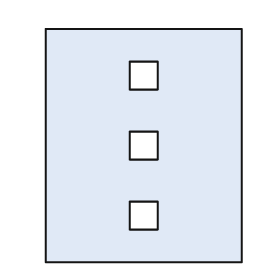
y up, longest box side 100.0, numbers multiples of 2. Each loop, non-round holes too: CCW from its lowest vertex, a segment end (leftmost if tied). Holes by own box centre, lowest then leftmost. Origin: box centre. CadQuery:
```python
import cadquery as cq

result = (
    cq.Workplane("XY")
    .moveTo(-42.0, -50.0)
    .lineTo(42.0, -50.0)
    .lineTo(42.0, 50.0)
    .lineTo(-42.0, 50.0)
    .close()
    .moveTo(-6.0, -36.0)
    .lineTo(6.0, -36.0)
    .lineTo(6.0, -24.0)
    .lineTo(-6.0, -24.0)
    .close()
    .moveTo(-6.0, -6.0)
    .lineTo(6.0, -6.0)
    .lineTo(6.0, 6.0)
    .lineTo(-6.0, 6.0)
    .close()
    .moveTo(-6.0, 24.0)
    .lineTo(6.0, 24.0)
    .lineTo(6.0, 36.0)
    .lineTo(-6.0, 36.0)
    .close()
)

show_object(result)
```